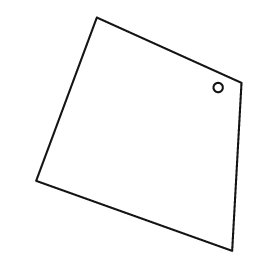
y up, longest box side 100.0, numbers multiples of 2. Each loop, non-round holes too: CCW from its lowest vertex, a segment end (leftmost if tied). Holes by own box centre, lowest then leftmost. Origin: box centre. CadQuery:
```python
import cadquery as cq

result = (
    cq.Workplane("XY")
    .moveTo(40.0, -50.0)
    .lineTo(44.0, 22.0)
    .lineTo(-18.0, 50.0)
    .lineTo(-44.0, -20.0)
    .close()
    .moveTo(34.0, 20.0)
    .circle(2.0)
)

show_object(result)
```